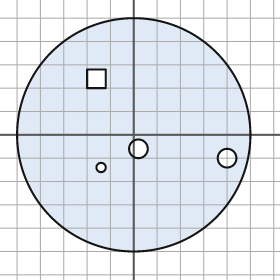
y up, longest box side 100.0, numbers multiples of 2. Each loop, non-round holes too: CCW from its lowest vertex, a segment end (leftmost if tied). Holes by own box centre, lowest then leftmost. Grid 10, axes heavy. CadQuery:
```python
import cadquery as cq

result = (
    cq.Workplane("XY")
    .moveTo(0.0, 0.0)
    .circle(50.0)
    .moveTo(-14.0, -14.0)
    .circle(2.0)
    .moveTo(40.0, -10.0)
    .circle(4.0)
    .moveTo(2.0, -6.0)
    .circle(4.0)
    .moveTo(-20.0, 20.0)
    .lineTo(-12.0, 20.0)
    .lineTo(-12.0, 28.0)
    .lineTo(-20.0, 28.0)
    .close()
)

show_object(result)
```